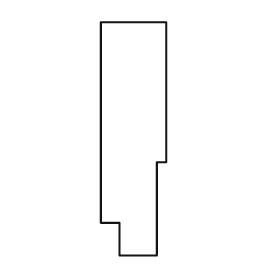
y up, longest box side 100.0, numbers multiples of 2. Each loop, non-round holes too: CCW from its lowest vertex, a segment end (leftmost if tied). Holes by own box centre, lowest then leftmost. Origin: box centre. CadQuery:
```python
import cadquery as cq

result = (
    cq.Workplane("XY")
    .moveTo(-6.0, -50.0)
    .lineTo(10.0, -50.0)
    .lineTo(10.0, -10.0)
    .lineTo(14.0, -10.0)
    .lineTo(14.0, 50.0)
    .lineTo(-14.0, 50.0)
    .lineTo(-14.0, -36.0)
    .lineTo(-6.0, -36.0)
    .close()
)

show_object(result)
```